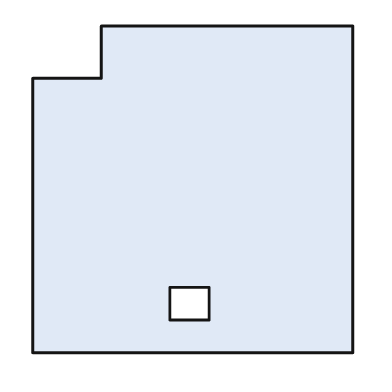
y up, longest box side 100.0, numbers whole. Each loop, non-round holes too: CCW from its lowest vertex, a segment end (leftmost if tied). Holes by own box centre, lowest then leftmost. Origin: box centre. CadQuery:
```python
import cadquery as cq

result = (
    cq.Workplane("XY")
    .moveTo(-49.0, -50.0)
    .lineTo(49.0, -50.0)
    .lineTo(49.0, 50.0)
    .lineTo(-28.0, 50.0)
    .lineTo(-28.0, 34.0)
    .lineTo(-49.0, 34.0)
    .close()
    .moveTo(-7.0, -40.0)
    .lineTo(5.0, -40.0)
    .lineTo(5.0, -30.0)
    .lineTo(-7.0, -30.0)
    .close()
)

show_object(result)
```